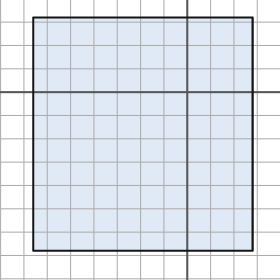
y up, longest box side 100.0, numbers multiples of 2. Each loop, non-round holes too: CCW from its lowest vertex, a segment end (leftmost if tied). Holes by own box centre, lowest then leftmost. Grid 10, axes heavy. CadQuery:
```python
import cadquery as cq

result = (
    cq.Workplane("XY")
    .moveTo(-66.0, -68.0)
    .lineTo(28.0, -68.0)
    .lineTo(28.0, 32.0)
    .lineTo(-66.0, 32.0)
    .close()
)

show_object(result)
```